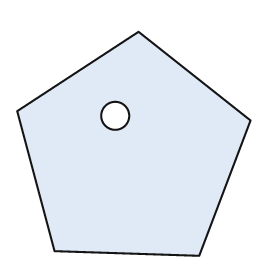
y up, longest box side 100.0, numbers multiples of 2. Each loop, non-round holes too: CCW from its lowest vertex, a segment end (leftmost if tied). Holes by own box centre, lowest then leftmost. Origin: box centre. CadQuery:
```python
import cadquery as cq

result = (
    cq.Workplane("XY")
    .moveTo(28.0, -48.0)
    .lineTo(50.0, 10.0)
    .lineTo(2.0, 48.0)
    .lineTo(-50.0, 14.0)
    .lineTo(-34.0, -46.0)
    .close()
    .moveTo(-8.0, 12.0)
    .circle(6.0)
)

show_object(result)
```